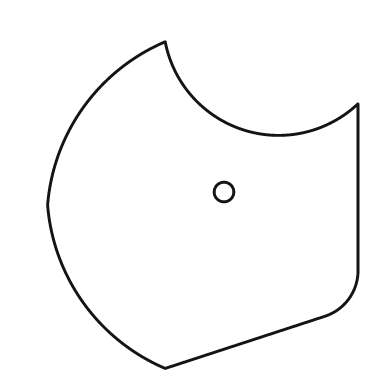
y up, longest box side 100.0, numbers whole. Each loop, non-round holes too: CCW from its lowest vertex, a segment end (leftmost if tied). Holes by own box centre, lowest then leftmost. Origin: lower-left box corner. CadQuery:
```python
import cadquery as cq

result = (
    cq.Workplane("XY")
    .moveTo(36.0, 0.0)
    .lineTo(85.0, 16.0)
    .threePointArc((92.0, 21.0), (95.0, 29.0))
    .lineTo(95.0, 81.0)
    .threePointArc((60.0, 73.0), (36.0, 100.0))
    .threePointArc((11.0, 80.0), (0.0, 50.0))
    .threePointArc((11.0, 20.0), (36.0, 0.0))
    .close()
    .moveTo(54.0, 54.0)
    .circle(3.0)
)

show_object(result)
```